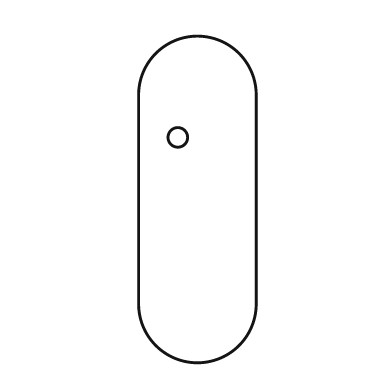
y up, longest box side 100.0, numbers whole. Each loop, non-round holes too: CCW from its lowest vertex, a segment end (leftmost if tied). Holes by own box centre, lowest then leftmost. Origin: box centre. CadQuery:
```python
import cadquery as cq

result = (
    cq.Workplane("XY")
    .moveTo(-18.0, -32.0)
    .threePointArc((0.0, -50.0), (18.0, -32.0))
    .lineTo(18.0, 32.0)
    .threePointArc((0.0, 50.0), (-18.0, 32.0))
    .close()
    .moveTo(-6.0, 19.0)
    .circle(3.0)
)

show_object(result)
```